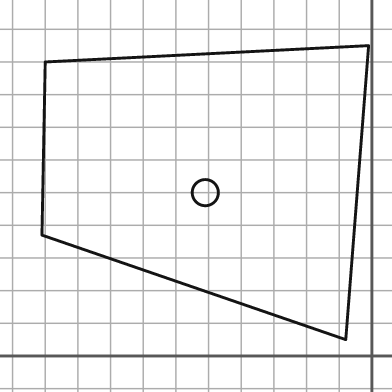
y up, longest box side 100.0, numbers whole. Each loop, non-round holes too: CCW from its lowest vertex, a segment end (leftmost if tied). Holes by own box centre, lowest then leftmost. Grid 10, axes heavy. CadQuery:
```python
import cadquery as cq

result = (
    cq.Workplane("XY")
    .moveTo(-8.0, 5.0)
    .lineTo(-1.0, 95.0)
    .lineTo(-100.0, 90.0)
    .lineTo(-101.0, 37.0)
    .close()
    .moveTo(-51.0, 50.0)
    .circle(4.0)
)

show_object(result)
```